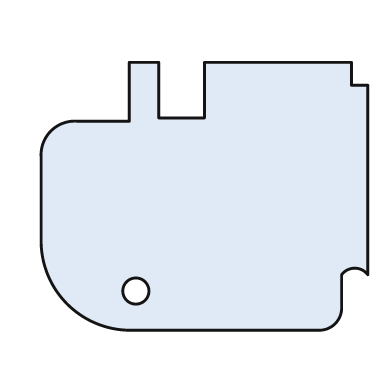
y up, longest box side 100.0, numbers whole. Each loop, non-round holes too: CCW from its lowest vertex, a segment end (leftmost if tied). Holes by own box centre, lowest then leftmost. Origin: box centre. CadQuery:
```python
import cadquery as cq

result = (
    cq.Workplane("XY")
    .moveTo(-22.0, -41.0)
    .lineTo(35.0, -41.0)
    .threePointArc((40.0, -39.0), (42.0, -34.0))
    .lineTo(42.0, -24.0)
    .threePointArc((46.0, -22.0), (50.0, -24.0))
    .lineTo(50.0, 34.0)
    .lineTo(45.0, 34.0)
    .lineTo(45.0, 41.0)
    .lineTo(0.0, 41.0)
    .lineTo(0.0, 24.0)
    .lineTo(-14.0, 24.0)
    .lineTo(-14.0, 41.0)
    .lineTo(-23.0, 41.0)
    .lineTo(-23.0, 23.0)
    .lineTo(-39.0, 23.0)
    .threePointArc((-47.0, 20.0), (-50.0, 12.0))
    .lineTo(-50.0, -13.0)
    .threePointArc((-42.0, -33.0), (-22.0, -41.0))
    .close()
    .moveTo(-21.0, -29.0)
    .circle(4.0)
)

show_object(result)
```